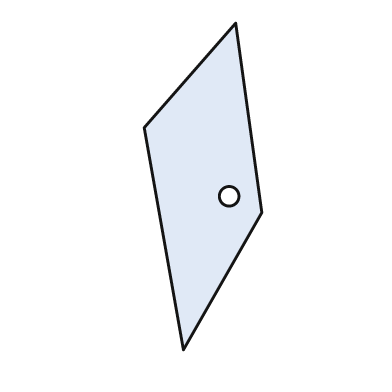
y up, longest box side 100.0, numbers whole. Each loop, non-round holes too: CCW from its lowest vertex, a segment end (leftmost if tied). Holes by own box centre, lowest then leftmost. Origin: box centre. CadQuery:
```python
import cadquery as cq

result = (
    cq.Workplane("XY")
    .moveTo(-6.0, -50.0)
    .lineTo(18.0, -8.0)
    .lineTo(10.0, 50.0)
    .lineTo(-18.0, 18.0)
    .close()
    .moveTo(8.0, -3.0)
    .circle(3.0)
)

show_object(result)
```